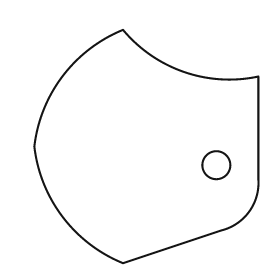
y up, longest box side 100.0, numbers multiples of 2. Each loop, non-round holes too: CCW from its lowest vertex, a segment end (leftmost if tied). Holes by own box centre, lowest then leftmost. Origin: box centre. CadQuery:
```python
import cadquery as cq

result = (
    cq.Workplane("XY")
    .moveTo(-10.0, -50.0)
    .lineTo(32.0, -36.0)
    .threePointArc((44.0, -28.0), (48.0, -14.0))
    .lineTo(48.0, 30.0)
    .threePointArc((16.0, 32.0), (-10.0, 50.0))
    .threePointArc((-36.0, 30.0), (-48.0, 0.0))
    .threePointArc((-36.0, -30.0), (-10.0, -50.0))
    .close()
    .moveTo(30.0, -8.0)
    .circle(6.0)
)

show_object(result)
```